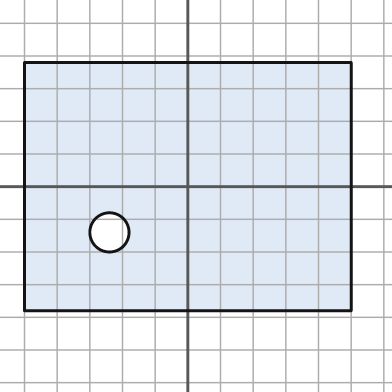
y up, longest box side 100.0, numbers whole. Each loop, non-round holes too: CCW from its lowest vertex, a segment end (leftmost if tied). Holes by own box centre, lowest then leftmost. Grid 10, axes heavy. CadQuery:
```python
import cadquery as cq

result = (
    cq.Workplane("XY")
    .moveTo(-50.0, -38.0)
    .lineTo(50.0, -38.0)
    .lineTo(50.0, 38.0)
    .lineTo(-50.0, 38.0)
    .close()
    .moveTo(-24.0, -14.0)
    .circle(6.0)
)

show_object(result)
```